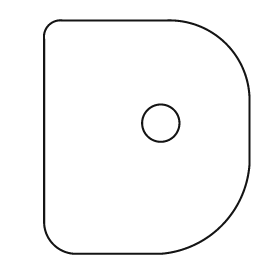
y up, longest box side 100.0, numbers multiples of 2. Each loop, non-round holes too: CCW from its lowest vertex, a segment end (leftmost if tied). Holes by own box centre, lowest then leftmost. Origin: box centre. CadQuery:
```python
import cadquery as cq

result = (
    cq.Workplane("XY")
    .moveTo(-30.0, -50.0)
    .lineTo(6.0, -50.0)
    .threePointArc((32.0, -38.0), (44.0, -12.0))
    .lineTo(44.0, 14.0)
    .threePointArc((34.0, 40.0), (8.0, 50.0))
    .lineTo(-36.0, 50.0)
    .threePointArc((-42.0, 48.0), (-44.0, 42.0))
    .lineTo(-44.0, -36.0)
    .threePointArc((-40.0, -46.0), (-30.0, -50.0))
    .close()
    .moveTo(6.0, 6.0)
    .circle(8.0)
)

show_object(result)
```